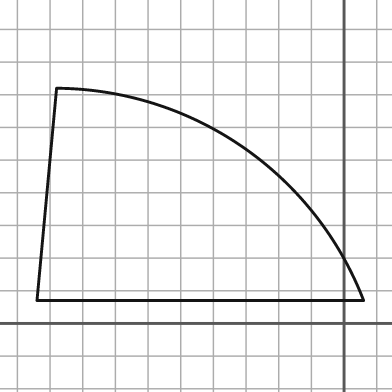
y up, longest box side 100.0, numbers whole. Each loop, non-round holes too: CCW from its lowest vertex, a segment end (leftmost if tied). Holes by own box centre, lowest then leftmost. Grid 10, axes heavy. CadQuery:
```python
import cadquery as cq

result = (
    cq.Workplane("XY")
    .moveTo(-94.0, 7.0)
    .lineTo(6.0, 7.0)
    .threePointArc((-31.0, 54.0), (-88.0, 72.0))
    .close()
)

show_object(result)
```